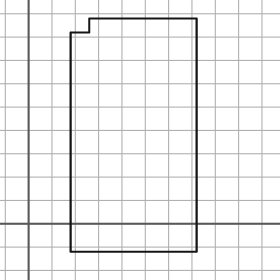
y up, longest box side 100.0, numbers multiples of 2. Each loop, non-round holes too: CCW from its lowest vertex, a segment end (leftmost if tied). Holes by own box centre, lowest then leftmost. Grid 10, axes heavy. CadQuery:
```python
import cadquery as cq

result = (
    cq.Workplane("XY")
    .moveTo(18.0, -12.0)
    .lineTo(72.0, -12.0)
    .lineTo(72.0, 88.0)
    .lineTo(26.0, 88.0)
    .lineTo(26.0, 82.0)
    .lineTo(18.0, 82.0)
    .close()
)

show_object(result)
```